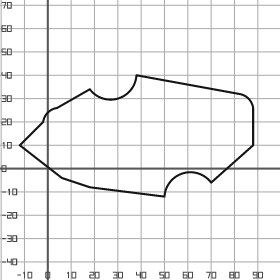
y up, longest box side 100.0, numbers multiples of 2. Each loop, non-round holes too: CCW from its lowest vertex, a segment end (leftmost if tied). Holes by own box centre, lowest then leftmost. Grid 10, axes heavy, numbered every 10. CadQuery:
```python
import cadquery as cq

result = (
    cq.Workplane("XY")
    .moveTo(50.0, -12.0)
    .threePointArc((58.0, -2.0), (70.0, -6.0))
    .lineTo(88.0, 10.0)
    .lineTo(88.0, 26.0)
    .threePointArc((86.0, 30.0), (82.0, 32.0))
    .lineTo(38.0, 40.0)
    .threePointArc((30.0, 30.0), (18.0, 34.0))
    .lineTo(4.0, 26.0)
    .threePointArc((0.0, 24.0), (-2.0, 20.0))
    .lineTo(-12.0, 10.0)
    .lineTo(6.0, -4.0)
    .lineTo(18.0, -8.0)
    .close()
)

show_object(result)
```